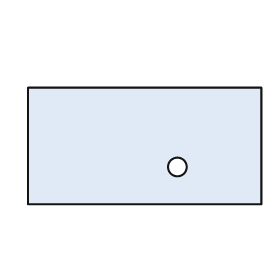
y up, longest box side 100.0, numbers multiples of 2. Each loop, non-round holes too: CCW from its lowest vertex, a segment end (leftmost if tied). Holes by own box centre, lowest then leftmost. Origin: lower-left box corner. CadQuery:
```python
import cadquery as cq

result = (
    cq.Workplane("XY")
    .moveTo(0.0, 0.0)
    .lineTo(100.0, 0.0)
    .lineTo(100.0, 50.0)
    .lineTo(0.0, 50.0)
    .close()
    .moveTo(64.0, 16.0)
    .circle(4.0)
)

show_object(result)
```